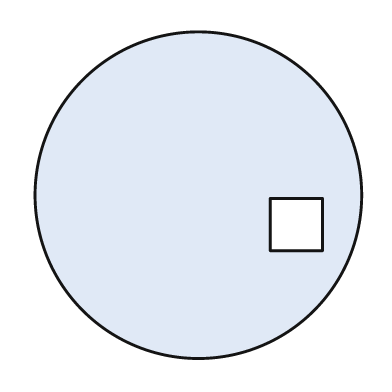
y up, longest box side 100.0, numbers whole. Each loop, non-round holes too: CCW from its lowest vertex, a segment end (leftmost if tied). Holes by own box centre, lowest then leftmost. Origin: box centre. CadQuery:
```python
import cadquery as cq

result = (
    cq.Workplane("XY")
    .moveTo(0.0, 0.0)
    .circle(50.0)
    .moveTo(22.0, -17.0)
    .lineTo(38.0, -17.0)
    .lineTo(38.0, -1.0)
    .lineTo(22.0, -1.0)
    .close()
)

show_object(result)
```